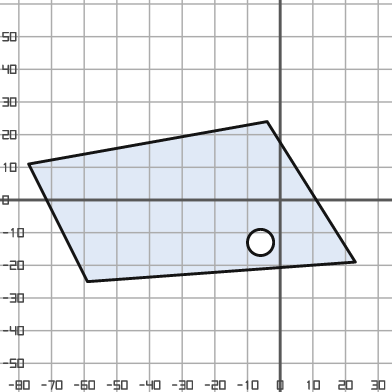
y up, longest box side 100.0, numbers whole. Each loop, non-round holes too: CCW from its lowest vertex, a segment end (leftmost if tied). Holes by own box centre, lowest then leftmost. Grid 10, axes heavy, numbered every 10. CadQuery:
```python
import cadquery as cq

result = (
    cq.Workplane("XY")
    .moveTo(-59.0, -25.0)
    .lineTo(23.0, -19.0)
    .lineTo(-4.0, 24.0)
    .lineTo(-77.0, 11.0)
    .close()
    .moveTo(-6.0, -13.0)
    .circle(4.0)
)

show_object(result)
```